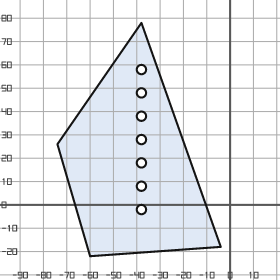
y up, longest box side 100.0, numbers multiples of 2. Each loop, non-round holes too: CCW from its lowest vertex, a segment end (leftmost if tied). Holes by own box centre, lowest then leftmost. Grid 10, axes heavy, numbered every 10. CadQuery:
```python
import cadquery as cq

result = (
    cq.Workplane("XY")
    .moveTo(-60.0, -22.0)
    .lineTo(-4.0, -18.0)
    .lineTo(-38.0, 78.0)
    .lineTo(-74.0, 26.0)
    .close()
    .moveTo(-38.0, -2.0)
    .circle(2.0)
    .moveTo(-38.0, 8.0)
    .circle(2.0)
    .moveTo(-38.0, 18.0)
    .circle(2.0)
    .moveTo(-38.0, 28.0)
    .circle(2.0)
    .moveTo(-38.0, 38.0)
    .circle(2.0)
    .moveTo(-38.0, 48.0)
    .circle(2.0)
    .moveTo(-38.0, 58.0)
    .circle(2.0)
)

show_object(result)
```